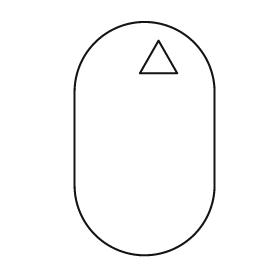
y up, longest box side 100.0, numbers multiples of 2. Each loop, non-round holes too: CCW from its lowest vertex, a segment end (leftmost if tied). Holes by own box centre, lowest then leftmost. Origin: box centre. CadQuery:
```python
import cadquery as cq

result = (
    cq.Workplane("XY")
    .moveTo(-30.0, -20.0)
    .threePointArc((0.0, -50.0), (30.0, -20.0))
    .lineTo(30.0, 20.0)
    .threePointArc((0.0, 50.0), (-30.0, 20.0))
    .close()
    .moveTo(-2.0, 28.0)
    .lineTo(14.0, 28.0)
    .lineTo(6.0, 42.0)
    .close()
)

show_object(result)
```